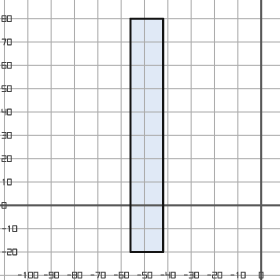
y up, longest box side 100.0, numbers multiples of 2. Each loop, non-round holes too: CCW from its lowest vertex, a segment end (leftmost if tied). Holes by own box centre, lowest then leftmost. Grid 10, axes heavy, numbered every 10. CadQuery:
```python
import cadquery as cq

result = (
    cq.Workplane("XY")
    .moveTo(-56.0, -20.0)
    .lineTo(-42.0, -20.0)
    .lineTo(-42.0, 80.0)
    .lineTo(-56.0, 80.0)
    .close()
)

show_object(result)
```